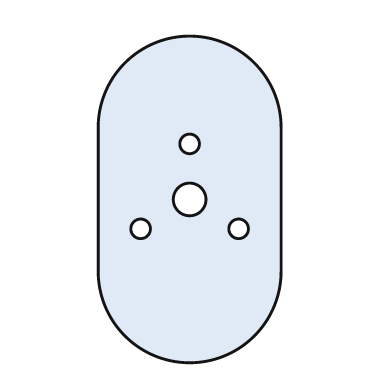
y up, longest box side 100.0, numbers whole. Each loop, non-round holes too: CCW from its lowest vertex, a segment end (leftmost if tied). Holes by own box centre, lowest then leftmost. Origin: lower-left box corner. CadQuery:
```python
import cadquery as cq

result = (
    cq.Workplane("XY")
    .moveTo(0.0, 28.0)
    .threePointArc((28.0, 0.0), (56.0, 28.0))
    .lineTo(56.0, 72.0)
    .threePointArc((28.0, 100.0), (0.0, 72.0))
    .close()
    .moveTo(13.0, 41.0)
    .circle(3.0)
    .moveTo(43.0, 41.0)
    .circle(3.0)
    .moveTo(28.0, 50.0)
    .circle(5.0)
    .moveTo(28.0, 67.0)
    .circle(3.0)
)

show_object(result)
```